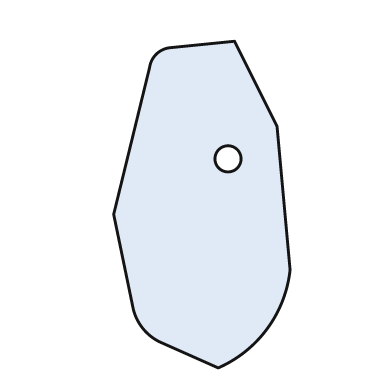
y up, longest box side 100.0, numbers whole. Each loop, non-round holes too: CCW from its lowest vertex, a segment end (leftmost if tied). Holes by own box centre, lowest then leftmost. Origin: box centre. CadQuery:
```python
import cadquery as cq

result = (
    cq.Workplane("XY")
    .moveTo(5.0, -50.0)
    .threePointArc((20.0, -38.0), (27.0, -20.0))
    .lineTo(23.0, 24.0)
    .lineTo(10.0, 50.0)
    .lineTo(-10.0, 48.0)
    .threePointArc((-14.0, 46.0), (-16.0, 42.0))
    .lineTo(-27.0, -3.0)
    .lineTo(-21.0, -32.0)
    .threePointArc((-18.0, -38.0), (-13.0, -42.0))
    .close()
    .moveTo(8.0, 14.0)
    .circle(4.0)
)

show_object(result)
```